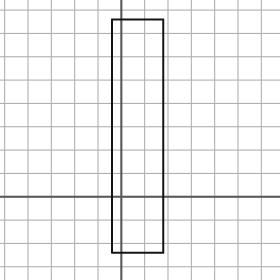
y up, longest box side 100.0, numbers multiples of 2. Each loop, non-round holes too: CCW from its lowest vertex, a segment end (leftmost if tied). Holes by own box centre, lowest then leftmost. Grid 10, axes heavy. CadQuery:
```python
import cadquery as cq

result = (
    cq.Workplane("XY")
    .moveTo(-4.0, -24.0)
    .lineTo(18.0, -24.0)
    .lineTo(18.0, 76.0)
    .lineTo(-4.0, 76.0)
    .close()
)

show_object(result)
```